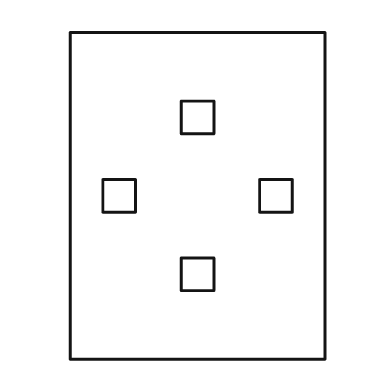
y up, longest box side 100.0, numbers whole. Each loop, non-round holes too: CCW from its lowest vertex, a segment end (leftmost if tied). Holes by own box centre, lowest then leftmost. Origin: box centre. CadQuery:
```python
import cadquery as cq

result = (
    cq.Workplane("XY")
    .moveTo(-39.0, -50.0)
    .lineTo(39.0, -50.0)
    .lineTo(39.0, 50.0)
    .lineTo(-39.0, 50.0)
    .close()
    .moveTo(-5.0, -29.0)
    .lineTo(5.0, -29.0)
    .lineTo(5.0, -19.0)
    .lineTo(-5.0, -19.0)
    .close()
    .moveTo(-29.0, -5.0)
    .lineTo(-19.0, -5.0)
    .lineTo(-19.0, 5.0)
    .lineTo(-29.0, 5.0)
    .close()
    .moveTo(19.0, -5.0)
    .lineTo(29.0, -5.0)
    .lineTo(29.0, 5.0)
    .lineTo(19.0, 5.0)
    .close()
    .moveTo(-5.0, 19.0)
    .lineTo(5.0, 19.0)
    .lineTo(5.0, 29.0)
    .lineTo(-5.0, 29.0)
    .close()
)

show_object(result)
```